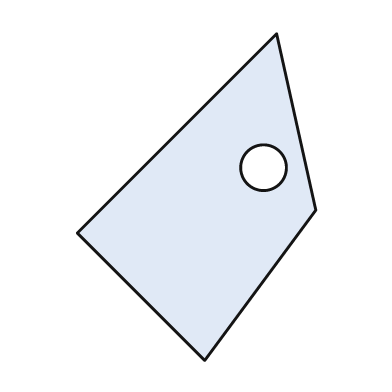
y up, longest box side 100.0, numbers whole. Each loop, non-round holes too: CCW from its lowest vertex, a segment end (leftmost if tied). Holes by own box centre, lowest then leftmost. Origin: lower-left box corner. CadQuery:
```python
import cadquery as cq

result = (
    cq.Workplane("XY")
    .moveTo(39.0, 0.0)
    .lineTo(73.0, 46.0)
    .lineTo(61.0, 100.0)
    .lineTo(0.0, 39.0)
    .close()
    .moveTo(57.0, 59.0)
    .circle(7.0)
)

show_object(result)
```